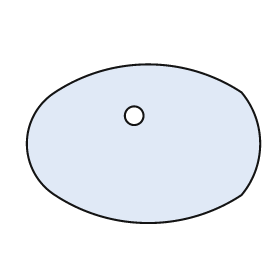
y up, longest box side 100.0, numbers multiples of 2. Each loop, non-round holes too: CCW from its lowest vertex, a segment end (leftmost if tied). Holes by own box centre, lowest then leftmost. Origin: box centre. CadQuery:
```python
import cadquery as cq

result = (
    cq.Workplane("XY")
    .moveTo(-38.0, -22.0)
    .threePointArc((2.0, -34.0), (42.0, -22.0))
    .threePointArc((50.0, 0.0), (42.0, 22.0))
    .threePointArc((2.0, 34.0), (-38.0, 22.0))
    .threePointArc((-50.0, 0.0), (-38.0, -22.0))
    .close()
    .moveTo(-4.0, 12.0)
    .circle(4.0)
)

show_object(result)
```